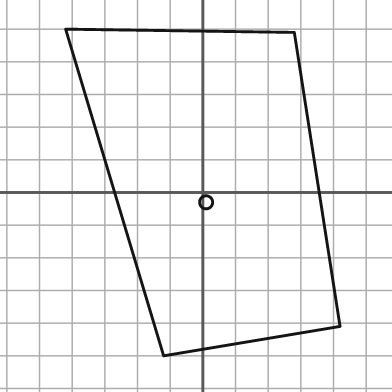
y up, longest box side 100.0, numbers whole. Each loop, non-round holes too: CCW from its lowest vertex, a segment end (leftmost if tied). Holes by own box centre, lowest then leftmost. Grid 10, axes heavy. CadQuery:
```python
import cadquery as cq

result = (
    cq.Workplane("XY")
    .moveTo(-12.0, -50.0)
    .lineTo(42.0, -41.0)
    .lineTo(28.0, 49.0)
    .lineTo(-42.0, 50.0)
    .close()
    .moveTo(1.0, -3.0)
    .circle(2.0)
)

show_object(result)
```